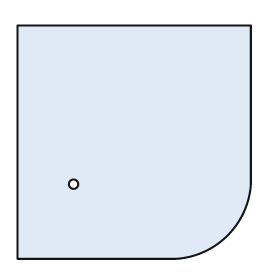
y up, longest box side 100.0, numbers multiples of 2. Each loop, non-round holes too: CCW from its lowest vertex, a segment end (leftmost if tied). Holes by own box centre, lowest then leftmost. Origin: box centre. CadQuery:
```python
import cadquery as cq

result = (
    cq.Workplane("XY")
    .moveTo(-50.0, -50.0)
    .lineTo(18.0, -50.0)
    .threePointArc((40.0, -40.0), (50.0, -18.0))
    .lineTo(50.0, 50.0)
    .lineTo(-50.0, 50.0)
    .close()
    .moveTo(-26.0, -18.0)
    .circle(2.0)
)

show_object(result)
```